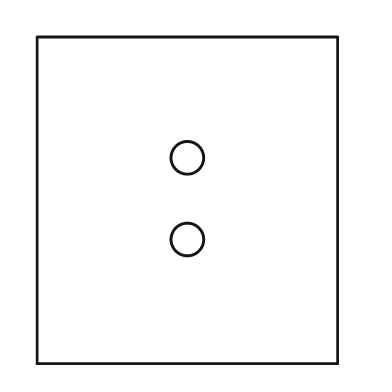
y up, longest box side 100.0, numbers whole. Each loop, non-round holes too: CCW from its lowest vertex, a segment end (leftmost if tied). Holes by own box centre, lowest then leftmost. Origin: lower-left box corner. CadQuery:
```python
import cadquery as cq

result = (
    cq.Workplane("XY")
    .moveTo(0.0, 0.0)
    .lineTo(92.0, 0.0)
    .lineTo(92.0, 100.0)
    .lineTo(0.0, 100.0)
    .close()
    .moveTo(46.0, 38.0)
    .circle(5.0)
    .moveTo(46.0, 63.0)
    .circle(5.0)
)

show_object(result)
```